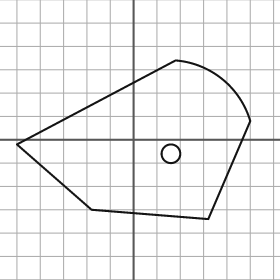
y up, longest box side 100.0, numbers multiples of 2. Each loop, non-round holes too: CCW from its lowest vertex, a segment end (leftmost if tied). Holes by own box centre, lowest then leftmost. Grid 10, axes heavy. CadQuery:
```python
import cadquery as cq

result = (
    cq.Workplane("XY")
    .moveTo(32.0, -34.0)
    .lineTo(50.0, 8.0)
    .threePointArc((38.0, 26.0), (18.0, 34.0))
    .lineTo(-50.0, -2.0)
    .lineTo(-18.0, -30.0)
    .close()
    .moveTo(16.0, -6.0)
    .circle(4.0)
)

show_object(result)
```